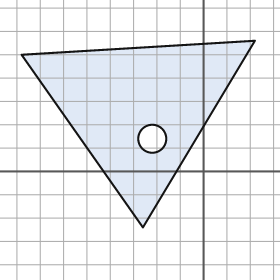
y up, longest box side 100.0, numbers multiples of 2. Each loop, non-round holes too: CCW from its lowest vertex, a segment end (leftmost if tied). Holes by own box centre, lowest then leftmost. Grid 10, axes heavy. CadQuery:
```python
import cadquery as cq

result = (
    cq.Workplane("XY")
    .moveTo(-26.0, -24.0)
    .lineTo(22.0, 56.0)
    .lineTo(-78.0, 50.0)
    .close()
    .moveTo(-22.0, 14.0)
    .circle(6.0)
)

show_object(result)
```